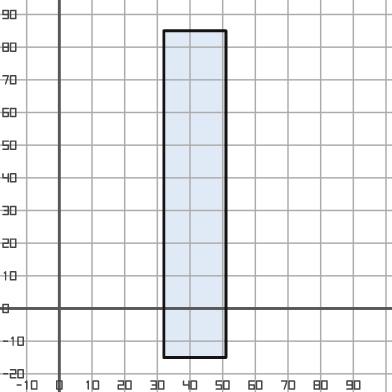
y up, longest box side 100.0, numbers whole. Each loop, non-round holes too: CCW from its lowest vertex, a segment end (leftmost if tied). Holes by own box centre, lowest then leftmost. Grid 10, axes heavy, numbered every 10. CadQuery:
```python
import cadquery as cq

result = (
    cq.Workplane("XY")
    .moveTo(32.0, -15.0)
    .lineTo(51.0, -15.0)
    .lineTo(51.0, 85.0)
    .lineTo(32.0, 85.0)
    .close()
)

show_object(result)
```